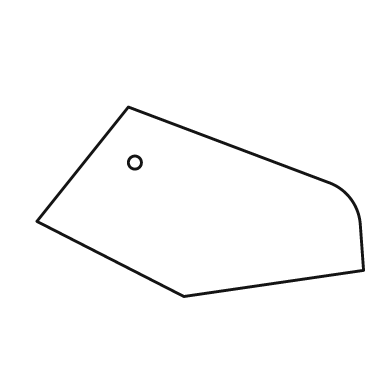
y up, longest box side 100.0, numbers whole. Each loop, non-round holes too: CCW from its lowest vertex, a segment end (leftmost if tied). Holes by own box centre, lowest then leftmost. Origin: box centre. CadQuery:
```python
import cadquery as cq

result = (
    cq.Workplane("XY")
    .moveTo(-5.0, -29.0)
    .lineTo(50.0, -21.0)
    .lineTo(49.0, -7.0)
    .threePointArc((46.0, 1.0), (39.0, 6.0))
    .lineTo(-22.0, 29.0)
    .lineTo(-50.0, -6.0)
    .close()
    .moveTo(-20.0, 12.0)
    .circle(2.0)
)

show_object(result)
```